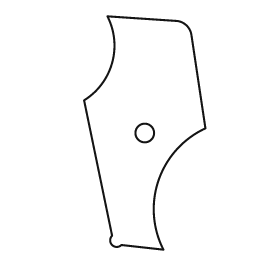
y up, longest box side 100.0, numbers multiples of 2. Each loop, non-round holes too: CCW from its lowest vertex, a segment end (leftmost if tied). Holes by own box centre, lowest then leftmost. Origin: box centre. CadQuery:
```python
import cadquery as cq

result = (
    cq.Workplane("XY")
    .moveTo(8.0, -50.0)
    .threePointArc((6.0, -20.0), (26.0, 2.0))
    .lineTo(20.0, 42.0)
    .threePointArc((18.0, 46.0), (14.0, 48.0))
    .lineTo(-16.0, 50.0)
    .threePointArc((-14.0, 30.0), (-26.0, 14.0))
    .lineTo(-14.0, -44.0)
    .threePointArc((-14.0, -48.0), (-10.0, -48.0))
    .close()
    .moveTo(0.0, 0.0)
    .circle(4.0)
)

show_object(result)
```